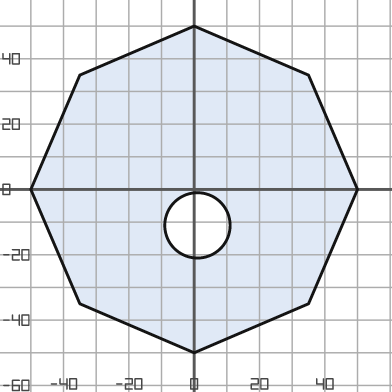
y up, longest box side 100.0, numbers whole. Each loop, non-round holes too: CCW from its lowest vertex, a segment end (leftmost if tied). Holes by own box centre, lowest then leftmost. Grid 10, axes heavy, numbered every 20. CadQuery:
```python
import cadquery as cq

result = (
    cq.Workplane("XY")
    .moveTo(0.0, -50.0)
    .lineTo(35.0, -35.0)
    .lineTo(50.0, 0.0)
    .lineTo(35.0, 35.0)
    .lineTo(0.0, 50.0)
    .lineTo(-35.0, 35.0)
    .lineTo(-50.0, 0.0)
    .lineTo(-35.0, -35.0)
    .close()
    .moveTo(1.0, -11.0)
    .circle(10.0)
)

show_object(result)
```